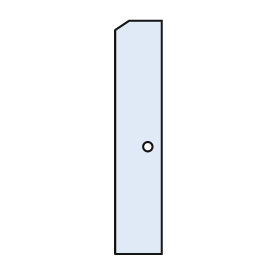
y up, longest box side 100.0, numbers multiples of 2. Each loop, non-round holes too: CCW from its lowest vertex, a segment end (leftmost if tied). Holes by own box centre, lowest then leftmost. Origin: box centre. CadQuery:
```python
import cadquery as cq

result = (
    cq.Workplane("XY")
    .moveTo(-10.0, -50.0)
    .lineTo(10.0, -50.0)
    .lineTo(10.0, 50.0)
    .lineTo(-4.0, 50.0)
    .lineTo(-10.0, 46.0)
    .close()
    .moveTo(4.0, -4.0)
    .circle(2.0)
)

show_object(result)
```